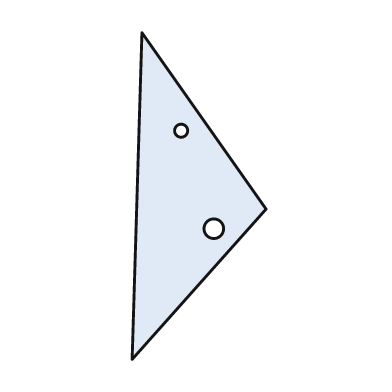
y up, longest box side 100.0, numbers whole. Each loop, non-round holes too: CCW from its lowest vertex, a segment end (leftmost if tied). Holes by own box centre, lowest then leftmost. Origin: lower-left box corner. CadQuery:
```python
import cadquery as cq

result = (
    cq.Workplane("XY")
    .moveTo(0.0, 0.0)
    .lineTo(41.0, 46.0)
    .lineTo(3.0, 100.0)
    .close()
    .moveTo(25.0, 40.0)
    .circle(3.0)
    .moveTo(15.0, 70.0)
    .circle(2.0)
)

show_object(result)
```